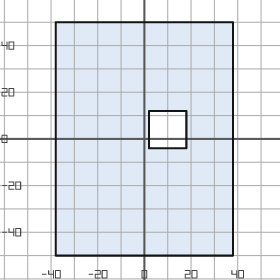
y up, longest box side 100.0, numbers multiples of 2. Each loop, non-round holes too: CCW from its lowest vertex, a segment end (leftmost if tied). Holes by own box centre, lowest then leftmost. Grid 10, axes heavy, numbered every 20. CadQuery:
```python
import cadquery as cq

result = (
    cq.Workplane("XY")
    .moveTo(-38.0, -50.0)
    .lineTo(38.0, -50.0)
    .lineTo(38.0, 50.0)
    .lineTo(-38.0, 50.0)
    .close()
    .moveTo(2.0, -4.0)
    .lineTo(18.0, -4.0)
    .lineTo(18.0, 12.0)
    .lineTo(2.0, 12.0)
    .close()
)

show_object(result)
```